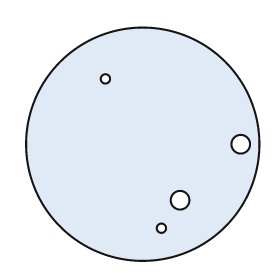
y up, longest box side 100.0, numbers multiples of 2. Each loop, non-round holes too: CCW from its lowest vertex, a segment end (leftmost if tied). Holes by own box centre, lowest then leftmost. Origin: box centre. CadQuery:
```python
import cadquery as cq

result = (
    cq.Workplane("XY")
    .moveTo(0.0, 0.0)
    .circle(50.0)
    .moveTo(8.0, -36.0)
    .circle(2.0)
    .moveTo(16.0, -24.0)
    .circle(4.0)
    .moveTo(42.0, 0.0)
    .circle(4.0)
    .moveTo(-16.0, 28.0)
    .circle(2.0)
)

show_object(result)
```